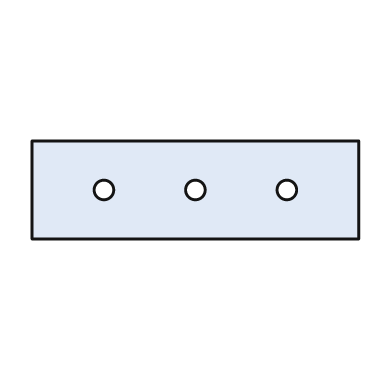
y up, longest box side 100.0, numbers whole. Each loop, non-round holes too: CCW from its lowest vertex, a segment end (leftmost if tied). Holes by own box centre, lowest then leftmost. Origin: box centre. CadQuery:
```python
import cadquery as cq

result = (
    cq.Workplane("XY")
    .moveTo(-50.0, -15.0)
    .lineTo(50.0, -15.0)
    .lineTo(50.0, 15.0)
    .lineTo(-50.0, 15.0)
    .close()
    .moveTo(-28.0, 0.0)
    .circle(3.0)
    .moveTo(0.0, 0.0)
    .circle(3.0)
    .moveTo(28.0, 0.0)
    .circle(3.0)
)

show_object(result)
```